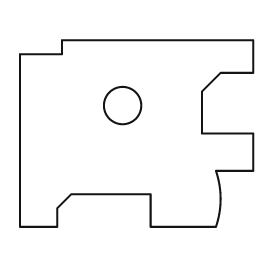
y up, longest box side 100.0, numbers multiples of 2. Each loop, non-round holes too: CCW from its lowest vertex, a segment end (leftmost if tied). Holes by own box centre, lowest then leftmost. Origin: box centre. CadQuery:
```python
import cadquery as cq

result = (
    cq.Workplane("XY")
    .moveTo(-50.0, -40.0)
    .lineTo(-34.0, -40.0)
    .lineTo(-34.0, -32.0)
    .lineTo(-28.0, -26.0)
    .lineTo(6.0, -26.0)
    .lineTo(6.0, -40.0)
    .lineTo(34.0, -40.0)
    .threePointArc((36.0, -28.0), (34.0, -16.0))
    .lineTo(50.0, -16.0)
    .lineTo(50.0, 0.0)
    .lineTo(28.0, 0.0)
    .lineTo(28.0, 18.0)
    .lineTo(36.0, 26.0)
    .lineTo(50.0, 26.0)
    .lineTo(50.0, 40.0)
    .lineTo(-32.0, 40.0)
    .lineTo(-32.0, 34.0)
    .lineTo(-50.0, 34.0)
    .close()
    .moveTo(-6.0, 12.0)
    .circle(8.0)
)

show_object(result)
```